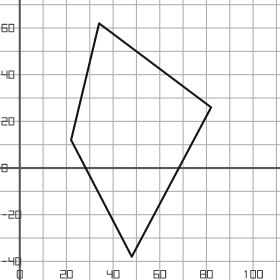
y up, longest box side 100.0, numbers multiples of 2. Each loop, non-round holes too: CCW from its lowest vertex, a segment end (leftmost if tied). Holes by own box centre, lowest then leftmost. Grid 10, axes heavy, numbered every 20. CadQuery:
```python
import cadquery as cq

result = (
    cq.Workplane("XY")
    .moveTo(48.0, -38.0)
    .lineTo(82.0, 26.0)
    .lineTo(34.0, 62.0)
    .lineTo(22.0, 12.0)
    .close()
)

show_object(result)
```